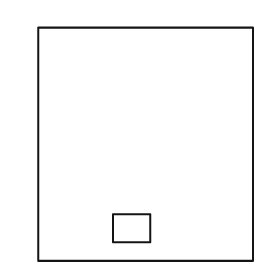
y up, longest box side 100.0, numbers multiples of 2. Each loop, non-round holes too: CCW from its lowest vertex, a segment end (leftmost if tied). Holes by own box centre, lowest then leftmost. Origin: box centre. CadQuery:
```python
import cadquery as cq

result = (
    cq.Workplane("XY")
    .moveTo(-46.0, -50.0)
    .lineTo(46.0, -50.0)
    .lineTo(46.0, 50.0)
    .lineTo(-46.0, 50.0)
    .close()
    .moveTo(-14.0, -42.0)
    .lineTo(2.0, -42.0)
    .lineTo(2.0, -30.0)
    .lineTo(-14.0, -30.0)
    .close()
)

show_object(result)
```